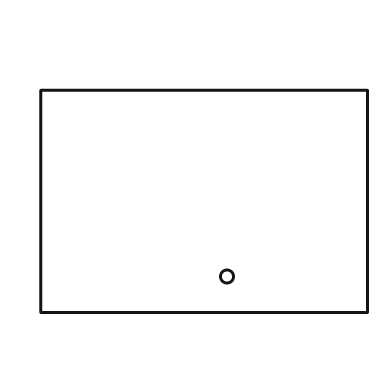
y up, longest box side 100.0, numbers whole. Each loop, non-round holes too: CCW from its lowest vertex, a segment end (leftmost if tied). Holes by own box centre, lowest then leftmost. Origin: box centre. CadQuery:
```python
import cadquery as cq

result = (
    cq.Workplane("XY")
    .moveTo(-50.0, -34.0)
    .lineTo(50.0, -34.0)
    .lineTo(50.0, 34.0)
    .lineTo(-50.0, 34.0)
    .close()
    .moveTo(7.0, -23.0)
    .circle(2.0)
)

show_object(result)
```